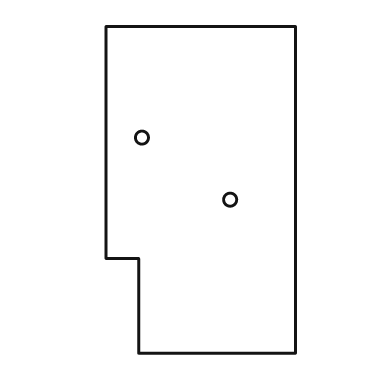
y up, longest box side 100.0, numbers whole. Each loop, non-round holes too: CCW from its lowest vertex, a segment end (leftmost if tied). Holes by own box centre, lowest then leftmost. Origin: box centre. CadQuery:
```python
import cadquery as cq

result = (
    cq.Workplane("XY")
    .moveTo(-19.0, -50.0)
    .lineTo(29.0, -50.0)
    .lineTo(29.0, 50.0)
    .lineTo(-29.0, 50.0)
    .lineTo(-29.0, -21.0)
    .lineTo(-19.0, -21.0)
    .close()
    .moveTo(9.0, -3.0)
    .circle(2.0)
    .moveTo(-18.0, 16.0)
    .circle(2.0)
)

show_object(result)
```